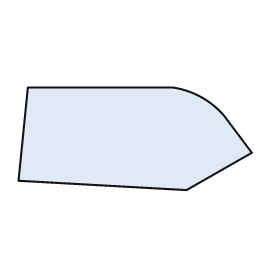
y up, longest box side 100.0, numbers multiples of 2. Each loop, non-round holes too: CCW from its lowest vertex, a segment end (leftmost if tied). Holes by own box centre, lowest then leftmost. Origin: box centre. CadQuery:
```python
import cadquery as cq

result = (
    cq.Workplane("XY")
    .moveTo(22.0, -22.0)
    .lineTo(50.0, -6.0)
    .lineTo(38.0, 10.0)
    .threePointArc((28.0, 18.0), (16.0, 22.0))
    .lineTo(-46.0, 22.0)
    .lineTo(-50.0, -18.0)
    .close()
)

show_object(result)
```